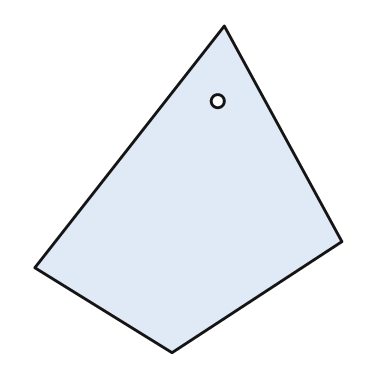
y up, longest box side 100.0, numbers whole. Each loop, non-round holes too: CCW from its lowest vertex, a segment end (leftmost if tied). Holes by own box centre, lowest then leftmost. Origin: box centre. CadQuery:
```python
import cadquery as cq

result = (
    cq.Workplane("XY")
    .moveTo(-5.0, -50.0)
    .lineTo(47.0, -16.0)
    .lineTo(11.0, 50.0)
    .lineTo(-47.0, -24.0)
    .close()
    .moveTo(9.0, 27.0)
    .circle(2.0)
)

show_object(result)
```